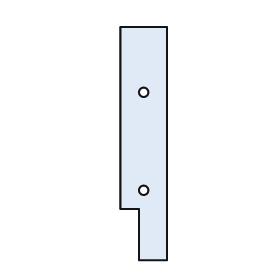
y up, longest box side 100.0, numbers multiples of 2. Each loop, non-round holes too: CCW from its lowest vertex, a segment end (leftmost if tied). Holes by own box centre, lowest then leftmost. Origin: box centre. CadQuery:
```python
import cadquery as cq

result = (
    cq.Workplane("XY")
    .moveTo(-2.0, -50.0)
    .lineTo(10.0, -50.0)
    .lineTo(10.0, 50.0)
    .lineTo(-10.0, 50.0)
    .lineTo(-10.0, -28.0)
    .lineTo(-2.0, -28.0)
    .close()
    .moveTo(0.0, -20.0)
    .circle(2.0)
    .moveTo(0.0, 22.0)
    .circle(2.0)
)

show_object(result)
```